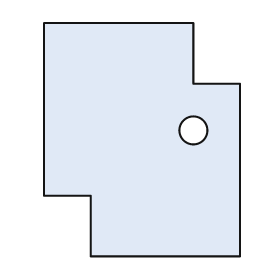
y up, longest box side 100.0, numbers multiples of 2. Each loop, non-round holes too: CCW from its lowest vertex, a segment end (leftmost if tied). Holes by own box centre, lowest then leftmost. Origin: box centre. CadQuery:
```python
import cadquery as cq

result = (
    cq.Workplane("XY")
    .moveTo(-22.0, -50.0)
    .lineTo(42.0, -50.0)
    .lineTo(42.0, 24.0)
    .lineTo(22.0, 24.0)
    .lineTo(22.0, 50.0)
    .lineTo(-42.0, 50.0)
    .lineTo(-42.0, -24.0)
    .lineTo(-22.0, -24.0)
    .close()
    .moveTo(22.0, 4.0)
    .circle(6.0)
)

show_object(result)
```